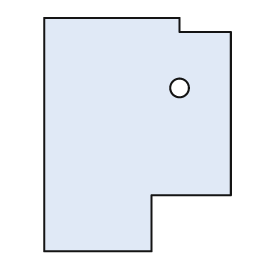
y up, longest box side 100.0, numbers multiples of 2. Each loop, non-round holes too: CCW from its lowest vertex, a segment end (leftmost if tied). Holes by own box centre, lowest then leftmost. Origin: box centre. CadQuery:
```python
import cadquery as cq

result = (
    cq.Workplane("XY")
    .moveTo(-40.0, -50.0)
    .lineTo(6.0, -50.0)
    .lineTo(6.0, -26.0)
    .lineTo(40.0, -26.0)
    .lineTo(40.0, 44.0)
    .lineTo(18.0, 44.0)
    .lineTo(18.0, 50.0)
    .lineTo(-40.0, 50.0)
    .close()
    .moveTo(18.0, 20.0)
    .circle(4.0)
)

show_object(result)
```